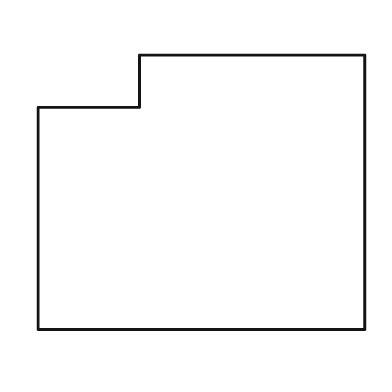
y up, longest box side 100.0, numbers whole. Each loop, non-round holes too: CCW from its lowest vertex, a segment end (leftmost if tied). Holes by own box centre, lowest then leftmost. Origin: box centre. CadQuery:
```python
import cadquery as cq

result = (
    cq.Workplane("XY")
    .moveTo(-50.0, -42.0)
    .lineTo(50.0, -42.0)
    .lineTo(50.0, 42.0)
    .lineTo(-19.0, 42.0)
    .lineTo(-19.0, 26.0)
    .lineTo(-50.0, 26.0)
    .close()
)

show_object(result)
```